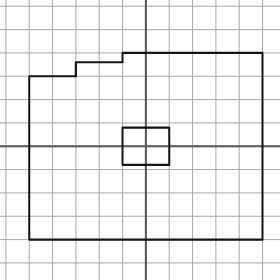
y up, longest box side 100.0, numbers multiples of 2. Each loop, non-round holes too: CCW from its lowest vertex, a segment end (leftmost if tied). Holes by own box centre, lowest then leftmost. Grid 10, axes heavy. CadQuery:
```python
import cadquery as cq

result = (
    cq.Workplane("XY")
    .moveTo(-50.0, -40.0)
    .lineTo(50.0, -40.0)
    .lineTo(50.0, 40.0)
    .lineTo(-10.0, 40.0)
    .lineTo(-10.0, 36.0)
    .lineTo(-30.0, 36.0)
    .lineTo(-30.0, 30.0)
    .lineTo(-50.0, 30.0)
    .close()
    .moveTo(-10.0, -8.0)
    .lineTo(10.0, -8.0)
    .lineTo(10.0, 8.0)
    .lineTo(-10.0, 8.0)
    .close()
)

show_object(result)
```